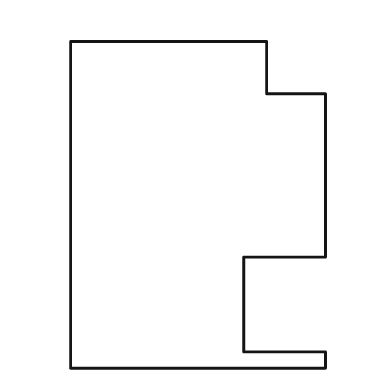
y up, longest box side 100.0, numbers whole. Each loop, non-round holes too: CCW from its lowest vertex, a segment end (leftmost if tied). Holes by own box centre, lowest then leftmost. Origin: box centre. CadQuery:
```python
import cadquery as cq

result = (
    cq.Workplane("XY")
    .moveTo(-39.0, -50.0)
    .lineTo(39.0, -50.0)
    .lineTo(39.0, -45.0)
    .lineTo(14.0, -45.0)
    .lineTo(14.0, -16.0)
    .lineTo(39.0, -16.0)
    .lineTo(39.0, 34.0)
    .lineTo(21.0, 34.0)
    .lineTo(21.0, 50.0)
    .lineTo(-39.0, 50.0)
    .close()
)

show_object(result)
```